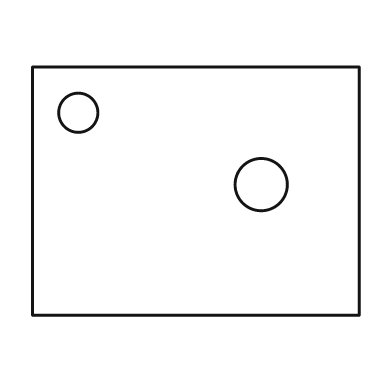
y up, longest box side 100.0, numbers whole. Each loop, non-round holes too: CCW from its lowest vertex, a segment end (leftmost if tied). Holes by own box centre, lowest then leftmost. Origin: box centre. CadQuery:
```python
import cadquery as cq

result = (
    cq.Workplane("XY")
    .moveTo(-50.0, -38.0)
    .lineTo(50.0, -38.0)
    .lineTo(50.0, 38.0)
    .lineTo(-50.0, 38.0)
    .close()
    .moveTo(20.0, 2.0)
    .circle(8.0)
    .moveTo(-36.0, 24.0)
    .circle(6.0)
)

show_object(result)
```